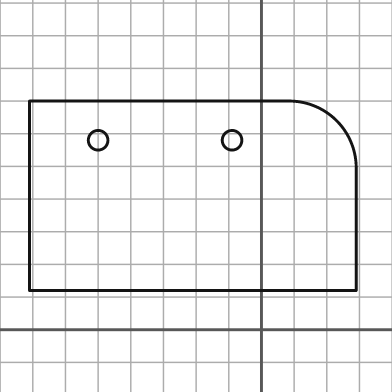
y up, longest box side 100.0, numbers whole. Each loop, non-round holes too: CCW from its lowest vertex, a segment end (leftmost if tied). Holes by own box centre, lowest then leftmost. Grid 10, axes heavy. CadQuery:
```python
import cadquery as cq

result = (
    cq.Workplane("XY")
    .moveTo(-71.0, 12.0)
    .lineTo(29.0, 12.0)
    .lineTo(29.0, 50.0)
    .threePointArc((23.0, 64.0), (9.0, 70.0))
    .lineTo(-71.0, 70.0)
    .close()
    .moveTo(-50.0, 58.0)
    .circle(3.0)
    .moveTo(-9.0, 58.0)
    .circle(3.0)
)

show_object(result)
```